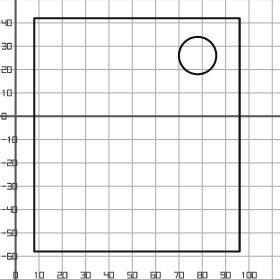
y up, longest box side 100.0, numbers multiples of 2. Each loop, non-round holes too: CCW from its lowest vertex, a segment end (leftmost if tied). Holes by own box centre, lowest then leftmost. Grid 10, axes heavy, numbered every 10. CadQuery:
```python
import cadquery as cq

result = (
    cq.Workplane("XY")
    .moveTo(8.0, -58.0)
    .lineTo(96.0, -58.0)
    .lineTo(96.0, 42.0)
    .lineTo(8.0, 42.0)
    .close()
    .moveTo(78.0, 26.0)
    .circle(8.0)
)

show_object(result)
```